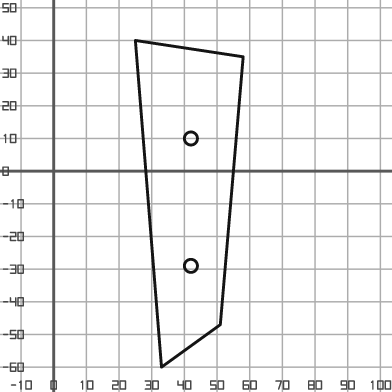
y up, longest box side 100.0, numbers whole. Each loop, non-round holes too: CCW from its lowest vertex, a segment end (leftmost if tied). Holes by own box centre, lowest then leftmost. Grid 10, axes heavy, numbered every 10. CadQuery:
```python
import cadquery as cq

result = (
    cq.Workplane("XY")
    .moveTo(33.0, -60.0)
    .lineTo(51.0, -47.0)
    .lineTo(58.0, 35.0)
    .lineTo(25.0, 40.0)
    .close()
    .moveTo(42.0, -29.0)
    .circle(2.0)
    .moveTo(42.0, 10.0)
    .circle(2.0)
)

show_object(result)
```